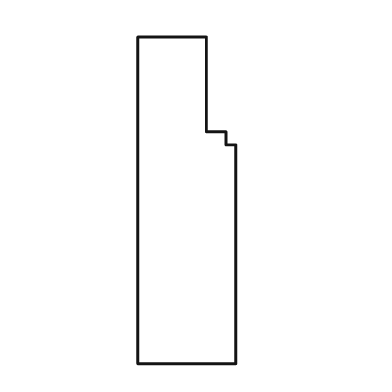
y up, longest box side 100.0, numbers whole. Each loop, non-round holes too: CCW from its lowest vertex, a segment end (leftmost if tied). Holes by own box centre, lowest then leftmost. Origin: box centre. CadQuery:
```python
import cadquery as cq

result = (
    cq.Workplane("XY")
    .moveTo(-15.0, -50.0)
    .lineTo(15.0, -50.0)
    .lineTo(15.0, 17.0)
    .lineTo(12.0, 17.0)
    .lineTo(12.0, 21.0)
    .lineTo(6.0, 21.0)
    .lineTo(6.0, 50.0)
    .lineTo(-15.0, 50.0)
    .close()
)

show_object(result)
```